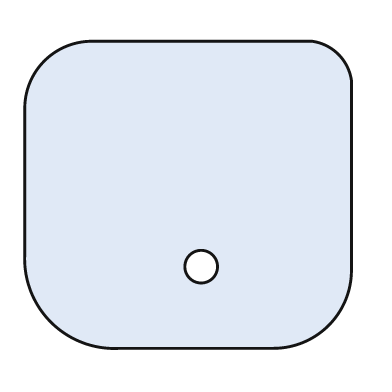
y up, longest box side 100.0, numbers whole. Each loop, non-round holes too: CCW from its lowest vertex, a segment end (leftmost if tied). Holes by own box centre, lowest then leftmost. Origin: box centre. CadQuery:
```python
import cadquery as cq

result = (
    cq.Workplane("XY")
    .moveTo(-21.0, -47.0)
    .lineTo(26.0, -47.0)
    .threePointArc((43.0, -40.0), (50.0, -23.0))
    .lineTo(50.0, 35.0)
    .threePointArc((46.0, 43.0), (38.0, 47.0))
    .lineTo(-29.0, 47.0)
    .threePointArc((-44.0, 41.0), (-50.0, 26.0))
    .lineTo(-50.0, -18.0)
    .threePointArc((-42.0, -39.0), (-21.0, -47.0))
    .close()
    .moveTo(4.0, -22.0)
    .circle(5.0)
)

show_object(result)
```